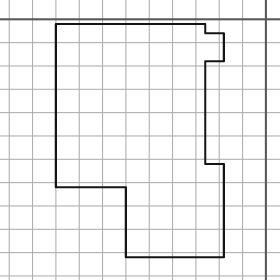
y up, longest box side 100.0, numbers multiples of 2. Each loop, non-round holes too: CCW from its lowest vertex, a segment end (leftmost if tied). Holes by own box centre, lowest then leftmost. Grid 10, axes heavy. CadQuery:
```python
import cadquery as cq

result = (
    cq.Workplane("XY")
    .moveTo(-60.0, -102.0)
    .lineTo(-18.0, -102.0)
    .lineTo(-18.0, -62.0)
    .lineTo(-26.0, -62.0)
    .lineTo(-26.0, -18.0)
    .lineTo(-18.0, -18.0)
    .lineTo(-18.0, -6.0)
    .lineTo(-26.0, -6.0)
    .lineTo(-26.0, -2.0)
    .lineTo(-90.0, -2.0)
    .lineTo(-90.0, -72.0)
    .lineTo(-60.0, -72.0)
    .close()
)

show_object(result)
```